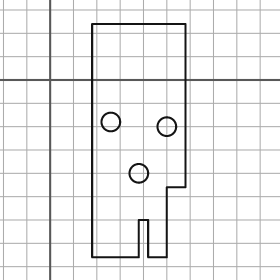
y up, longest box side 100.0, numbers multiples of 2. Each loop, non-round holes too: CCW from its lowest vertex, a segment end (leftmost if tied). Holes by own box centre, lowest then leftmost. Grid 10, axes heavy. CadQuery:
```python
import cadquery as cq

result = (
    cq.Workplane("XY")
    .moveTo(18.0, -76.0)
    .lineTo(38.0, -76.0)
    .lineTo(38.0, -60.0)
    .lineTo(42.0, -60.0)
    .lineTo(42.0, -76.0)
    .lineTo(50.0, -76.0)
    .lineTo(50.0, -46.0)
    .lineTo(58.0, -46.0)
    .lineTo(58.0, 24.0)
    .lineTo(18.0, 24.0)
    .close()
    .moveTo(38.0, -40.0)
    .circle(4.0)
    .moveTo(50.0, -20.0)
    .circle(4.0)
    .moveTo(26.0, -18.0)
    .circle(4.0)
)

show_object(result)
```